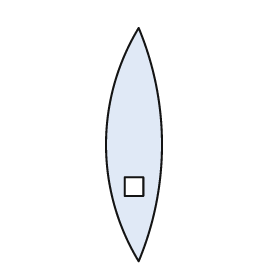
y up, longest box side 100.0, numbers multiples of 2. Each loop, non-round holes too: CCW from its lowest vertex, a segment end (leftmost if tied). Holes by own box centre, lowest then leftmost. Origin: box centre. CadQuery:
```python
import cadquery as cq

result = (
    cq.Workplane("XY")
    .moveTo(2.0, -50.0)
    .threePointArc((12.0, 0.0), (2.0, 50.0))
    .threePointArc((-12.0, 0.0), (2.0, -50.0))
    .close()
    .moveTo(-4.0, -22.0)
    .lineTo(4.0, -22.0)
    .lineTo(4.0, -14.0)
    .lineTo(-4.0, -14.0)
    .close()
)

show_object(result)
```